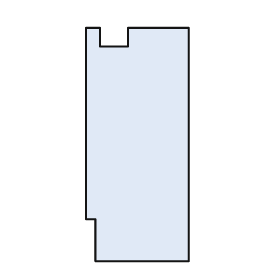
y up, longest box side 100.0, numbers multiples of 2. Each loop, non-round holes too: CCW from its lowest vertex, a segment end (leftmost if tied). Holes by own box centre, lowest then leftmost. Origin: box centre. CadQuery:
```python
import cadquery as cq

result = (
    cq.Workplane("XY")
    .moveTo(-18.0, -50.0)
    .lineTo(22.0, -50.0)
    .lineTo(22.0, 50.0)
    .lineTo(-4.0, 50.0)
    .lineTo(-4.0, 42.0)
    .lineTo(-16.0, 42.0)
    .lineTo(-16.0, 50.0)
    .lineTo(-22.0, 50.0)
    .lineTo(-22.0, -32.0)
    .lineTo(-18.0, -32.0)
    .close()
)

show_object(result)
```